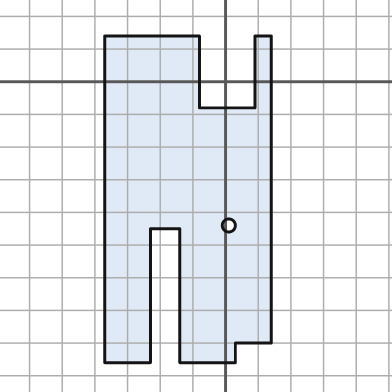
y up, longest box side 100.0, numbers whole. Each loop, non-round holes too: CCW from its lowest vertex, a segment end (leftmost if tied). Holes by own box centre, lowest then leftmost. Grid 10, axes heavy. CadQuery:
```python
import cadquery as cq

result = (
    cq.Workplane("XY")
    .moveTo(-37.0, -86.0)
    .lineTo(-23.0, -86.0)
    .lineTo(-23.0, -45.0)
    .lineTo(-14.0, -45.0)
    .lineTo(-14.0, -86.0)
    .lineTo(3.0, -86.0)
    .lineTo(3.0, -80.0)
    .lineTo(14.0, -80.0)
    .lineTo(14.0, 14.0)
    .lineTo(9.0, 14.0)
    .lineTo(9.0, -8.0)
    .lineTo(-8.0, -8.0)
    .lineTo(-8.0, 14.0)
    .lineTo(-37.0, 14.0)
    .close()
    .moveTo(1.0, -44.0)
    .circle(2.0)
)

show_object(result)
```